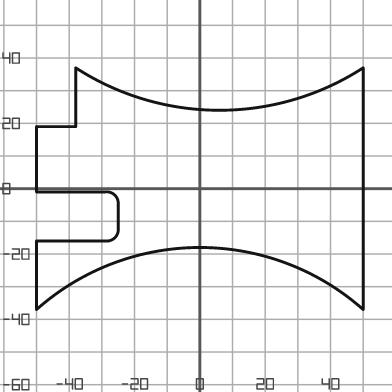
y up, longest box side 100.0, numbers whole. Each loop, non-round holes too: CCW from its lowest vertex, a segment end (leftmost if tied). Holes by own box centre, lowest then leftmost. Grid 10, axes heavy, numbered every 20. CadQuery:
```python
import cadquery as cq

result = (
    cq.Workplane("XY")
    .moveTo(-50.0, -37.0)
    .threePointArc((0.0, -18.0), (50.0, -37.0))
    .lineTo(50.0, 37.0)
    .threePointArc((6.0, 24.0), (-38.0, 37.0))
    .lineTo(-38.0, 19.0)
    .lineTo(-50.0, 19.0)
    .lineTo(-50.0, -1.0)
    .lineTo(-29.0, -1.0)
    .threePointArc((-26.0, -2.0), (-25.0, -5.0))
    .lineTo(-25.0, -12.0)
    .threePointArc((-26.0, -15.0), (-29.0, -16.0))
    .lineTo(-50.0, -16.0)
    .close()
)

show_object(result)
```